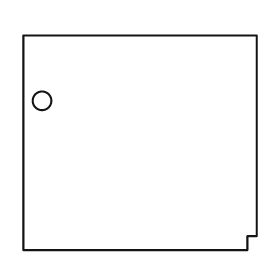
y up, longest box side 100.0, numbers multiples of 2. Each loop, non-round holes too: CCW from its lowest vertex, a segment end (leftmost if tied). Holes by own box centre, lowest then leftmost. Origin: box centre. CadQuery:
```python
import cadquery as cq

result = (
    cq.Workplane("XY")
    .moveTo(-50.0, -46.0)
    .lineTo(46.0, -46.0)
    .lineTo(46.0, -40.0)
    .lineTo(50.0, -40.0)
    .lineTo(50.0, 46.0)
    .lineTo(-50.0, 46.0)
    .close()
    .moveTo(-42.0, 18.0)
    .circle(4.0)
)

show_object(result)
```